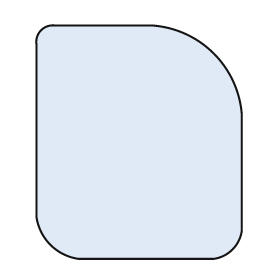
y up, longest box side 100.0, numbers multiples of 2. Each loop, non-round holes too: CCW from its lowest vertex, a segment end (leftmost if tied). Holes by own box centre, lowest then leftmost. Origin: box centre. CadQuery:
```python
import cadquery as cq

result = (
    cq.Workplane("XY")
    .moveTo(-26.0, -50.0)
    .lineTo(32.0, -50.0)
    .threePointArc((40.0, -46.0), (44.0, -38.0))
    .lineTo(44.0, 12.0)
    .threePointArc((32.0, 38.0), (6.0, 50.0))
    .lineTo(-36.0, 50.0)
    .threePointArc((-42.0, 48.0), (-44.0, 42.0))
    .lineTo(-44.0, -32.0)
    .threePointArc((-38.0, -44.0), (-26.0, -50.0))
    .close()
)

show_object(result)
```